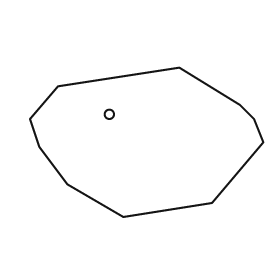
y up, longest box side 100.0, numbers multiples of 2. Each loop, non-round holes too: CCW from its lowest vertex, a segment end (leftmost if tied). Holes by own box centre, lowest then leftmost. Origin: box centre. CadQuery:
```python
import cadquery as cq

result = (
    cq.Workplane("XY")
    .moveTo(-10.0, -32.0)
    .lineTo(28.0, -26.0)
    .lineTo(50.0, 0.0)
    .lineTo(46.0, 10.0)
    .lineTo(40.0, 16.0)
    .lineTo(14.0, 32.0)
    .lineTo(-38.0, 24.0)
    .lineTo(-50.0, 10.0)
    .lineTo(-46.0, -2.0)
    .lineTo(-34.0, -18.0)
    .close()
    .moveTo(-16.0, 12.0)
    .circle(2.0)
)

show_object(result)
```